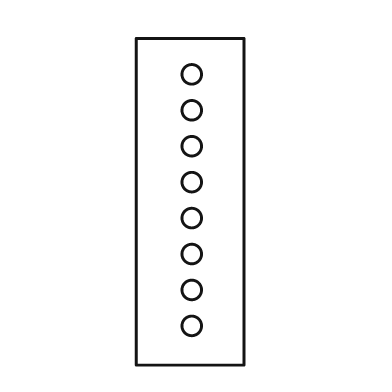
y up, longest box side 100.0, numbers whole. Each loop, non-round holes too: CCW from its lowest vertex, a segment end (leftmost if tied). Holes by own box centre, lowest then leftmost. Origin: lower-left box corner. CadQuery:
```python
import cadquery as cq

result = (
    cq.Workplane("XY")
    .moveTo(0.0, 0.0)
    .lineTo(33.0, 0.0)
    .lineTo(33.0, 100.0)
    .lineTo(0.0, 100.0)
    .close()
    .moveTo(17.0, 12.0)
    .circle(3.0)
    .moveTo(17.0, 23.0)
    .circle(3.0)
    .moveTo(17.0, 34.0)
    .circle(3.0)
    .moveTo(17.0, 45.0)
    .circle(3.0)
    .moveTo(17.0, 56.0)
    .circle(3.0)
    .moveTo(17.0, 67.0)
    .circle(3.0)
    .moveTo(17.0, 78.0)
    .circle(3.0)
    .moveTo(17.0, 89.0)
    .circle(3.0)
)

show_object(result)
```